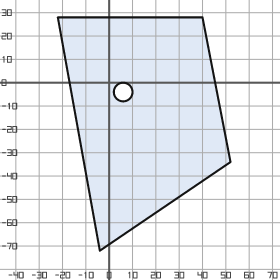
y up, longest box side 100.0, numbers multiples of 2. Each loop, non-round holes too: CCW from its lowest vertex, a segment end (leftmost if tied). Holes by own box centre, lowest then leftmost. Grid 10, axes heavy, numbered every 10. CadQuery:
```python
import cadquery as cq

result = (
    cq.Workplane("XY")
    .moveTo(-4.0, -72.0)
    .lineTo(52.0, -34.0)
    .lineTo(40.0, 28.0)
    .lineTo(-22.0, 28.0)
    .close()
    .moveTo(6.0, -4.0)
    .circle(4.0)
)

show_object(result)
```